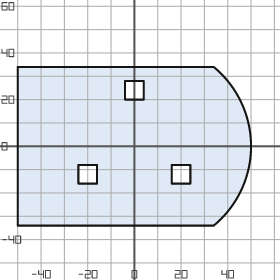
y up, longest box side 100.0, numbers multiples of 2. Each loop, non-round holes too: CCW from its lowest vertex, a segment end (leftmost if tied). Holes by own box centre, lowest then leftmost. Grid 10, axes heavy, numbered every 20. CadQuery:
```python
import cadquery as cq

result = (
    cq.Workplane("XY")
    .moveTo(-50.0, -34.0)
    .lineTo(34.0, -34.0)
    .threePointArc((50.0, 0.0), (34.0, 34.0))
    .lineTo(-50.0, 34.0)
    .close()
    .moveTo(-24.0, -16.0)
    .lineTo(-16.0, -16.0)
    .lineTo(-16.0, -8.0)
    .lineTo(-24.0, -8.0)
    .close()
    .moveTo(16.0, -16.0)
    .lineTo(24.0, -16.0)
    .lineTo(24.0, -8.0)
    .lineTo(16.0, -8.0)
    .close()
    .moveTo(-4.0, 20.0)
    .lineTo(4.0, 20.0)
    .lineTo(4.0, 28.0)
    .lineTo(-4.0, 28.0)
    .close()
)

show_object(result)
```